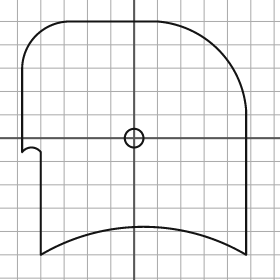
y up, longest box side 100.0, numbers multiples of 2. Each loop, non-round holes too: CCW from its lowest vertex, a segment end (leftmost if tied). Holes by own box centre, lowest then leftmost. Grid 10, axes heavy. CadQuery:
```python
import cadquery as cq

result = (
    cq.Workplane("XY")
    .moveTo(-40.0, -50.0)
    .threePointArc((4.0, -38.0), (48.0, -50.0))
    .lineTo(48.0, 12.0)
    .threePointArc((36.0, 38.0), (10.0, 50.0))
    .lineTo(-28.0, 50.0)
    .threePointArc((-42.0, 44.0), (-48.0, 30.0))
    .lineTo(-48.0, -6.0)
    .threePointArc((-44.0, -4.0), (-40.0, -6.0))
    .close()
    .moveTo(0.0, 0.0)
    .circle(4.0)
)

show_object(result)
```